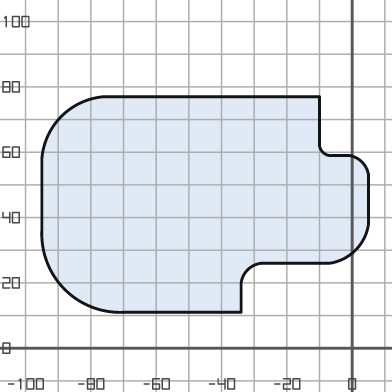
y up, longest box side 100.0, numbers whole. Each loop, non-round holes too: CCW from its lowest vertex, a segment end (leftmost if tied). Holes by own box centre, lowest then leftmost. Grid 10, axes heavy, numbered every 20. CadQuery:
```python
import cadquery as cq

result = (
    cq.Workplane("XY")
    .moveTo(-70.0, 11.0)
    .lineTo(-34.0, 11.0)
    .lineTo(-34.0, 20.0)
    .threePointArc((-32.0, 24.0), (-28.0, 26.0))
    .lineTo(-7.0, 26.0)
    .threePointArc((1.0, 30.0), (5.0, 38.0))
    .lineTo(5.0, 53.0)
    .threePointArc((3.0, 57.0), (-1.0, 59.0))
    .lineTo(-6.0, 59.0)
    .threePointArc((-9.0, 60.0), (-10.0, 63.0))
    .lineTo(-10.0, 77.0)
    .lineTo(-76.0, 77.0)
    .threePointArc((-89.0, 71.0), (-95.0, 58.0))
    .lineTo(-95.0, 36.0)
    .threePointArc((-88.0, 18.0), (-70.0, 11.0))
    .close()
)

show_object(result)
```